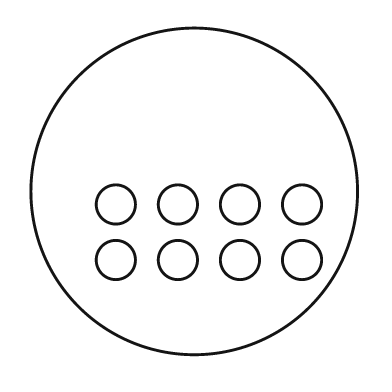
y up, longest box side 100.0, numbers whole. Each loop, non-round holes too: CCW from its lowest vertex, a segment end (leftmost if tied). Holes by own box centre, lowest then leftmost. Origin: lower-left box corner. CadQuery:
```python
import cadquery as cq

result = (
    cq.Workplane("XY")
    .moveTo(50.0, 50.0)
    .circle(50.0)
    .moveTo(26.0, 29.0)
    .circle(6.0)
    .moveTo(45.0, 29.0)
    .circle(6.0)
    .moveTo(64.0, 29.0)
    .circle(6.0)
    .moveTo(83.0, 29.0)
    .circle(6.0)
    .moveTo(26.0, 46.0)
    .circle(6.0)
    .moveTo(45.0, 46.0)
    .circle(6.0)
    .moveTo(64.0, 46.0)
    .circle(6.0)
    .moveTo(83.0, 46.0)
    .circle(6.0)
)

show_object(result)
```